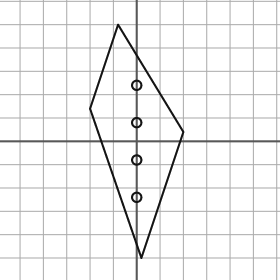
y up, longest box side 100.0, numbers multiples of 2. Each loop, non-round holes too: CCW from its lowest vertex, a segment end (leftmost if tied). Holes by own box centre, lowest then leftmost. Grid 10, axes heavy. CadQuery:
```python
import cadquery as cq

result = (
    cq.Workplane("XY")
    .moveTo(2.0, -50.0)
    .lineTo(20.0, 4.0)
    .lineTo(-8.0, 50.0)
    .lineTo(-20.0, 14.0)
    .close()
    .moveTo(0.0, -24.0)
    .circle(2.0)
    .moveTo(0.0, -8.0)
    .circle(2.0)
    .moveTo(0.0, 8.0)
    .circle(2.0)
    .moveTo(0.0, 24.0)
    .circle(2.0)
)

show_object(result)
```